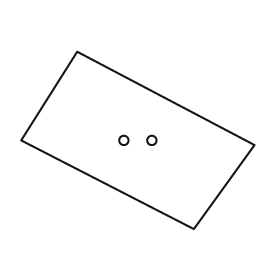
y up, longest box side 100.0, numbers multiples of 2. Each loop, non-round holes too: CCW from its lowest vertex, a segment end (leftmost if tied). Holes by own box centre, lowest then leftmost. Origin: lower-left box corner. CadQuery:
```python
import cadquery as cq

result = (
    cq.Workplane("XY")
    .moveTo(74.0, 0.0)
    .lineTo(100.0, 36.0)
    .lineTo(24.0, 76.0)
    .lineTo(0.0, 38.0)
    .close()
    .moveTo(44.0, 38.0)
    .circle(2.0)
    .moveTo(56.0, 38.0)
    .circle(2.0)
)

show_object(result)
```